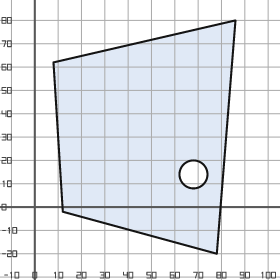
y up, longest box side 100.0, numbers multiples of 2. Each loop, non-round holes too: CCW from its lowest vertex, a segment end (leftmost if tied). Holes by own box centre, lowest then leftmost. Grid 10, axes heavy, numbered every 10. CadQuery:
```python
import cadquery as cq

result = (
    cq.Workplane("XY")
    .moveTo(78.0, -20.0)
    .lineTo(86.0, 80.0)
    .lineTo(8.0, 62.0)
    .lineTo(12.0, -2.0)
    .close()
    .moveTo(68.0, 14.0)
    .circle(6.0)
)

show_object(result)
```